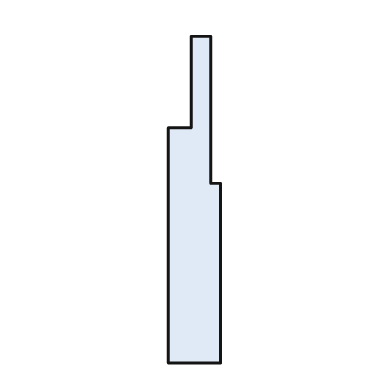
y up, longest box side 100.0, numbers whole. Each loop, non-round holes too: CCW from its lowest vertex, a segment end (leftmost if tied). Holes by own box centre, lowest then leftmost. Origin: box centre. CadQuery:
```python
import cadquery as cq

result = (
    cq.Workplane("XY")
    .moveTo(-8.0, -50.0)
    .lineTo(8.0, -50.0)
    .lineTo(8.0, 5.0)
    .lineTo(5.0, 5.0)
    .lineTo(5.0, 50.0)
    .lineTo(-1.0, 50.0)
    .lineTo(-1.0, 22.0)
    .lineTo(-8.0, 22.0)
    .close()
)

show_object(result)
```